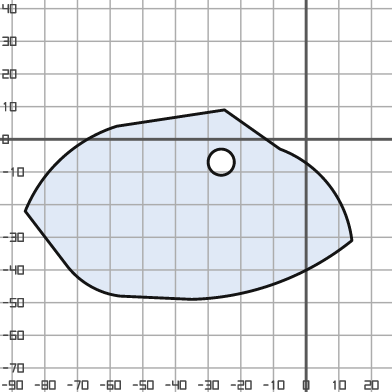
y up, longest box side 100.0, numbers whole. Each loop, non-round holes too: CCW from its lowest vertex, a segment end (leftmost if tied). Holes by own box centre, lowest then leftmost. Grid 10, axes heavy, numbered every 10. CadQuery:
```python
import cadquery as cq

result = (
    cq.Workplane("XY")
    .moveTo(-35.0, -49.0)
    .threePointArc((-9.0, -44.0), (14.0, -31.0))
    .threePointArc((7.0, -14.0), (-8.0, -3.0))
    .lineTo(-25.0, 9.0)
    .lineTo(-58.0, 4.0)
    .threePointArc((-75.0, -6.0), (-86.0, -22.0))
    .lineTo(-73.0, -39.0)
    .threePointArc((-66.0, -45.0), (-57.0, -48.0))
    .close()
    .moveTo(-26.0, -7.0)
    .circle(4.0)
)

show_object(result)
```